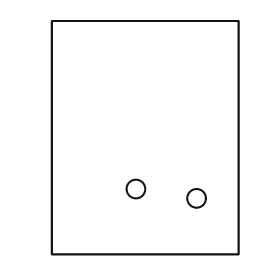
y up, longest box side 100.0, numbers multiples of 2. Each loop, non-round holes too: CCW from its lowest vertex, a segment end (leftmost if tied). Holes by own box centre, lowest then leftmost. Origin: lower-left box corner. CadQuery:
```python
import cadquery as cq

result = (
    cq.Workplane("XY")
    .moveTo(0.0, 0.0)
    .lineTo(80.0, 0.0)
    .lineTo(80.0, 100.0)
    .lineTo(0.0, 100.0)
    .close()
    .moveTo(62.0, 24.0)
    .circle(4.0)
    .moveTo(36.0, 28.0)
    .circle(4.0)
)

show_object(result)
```